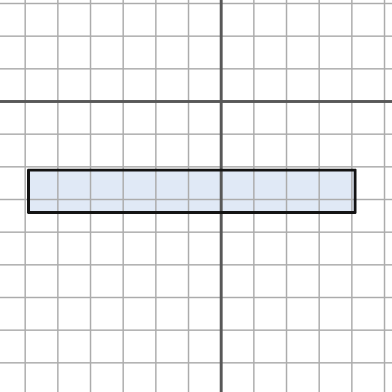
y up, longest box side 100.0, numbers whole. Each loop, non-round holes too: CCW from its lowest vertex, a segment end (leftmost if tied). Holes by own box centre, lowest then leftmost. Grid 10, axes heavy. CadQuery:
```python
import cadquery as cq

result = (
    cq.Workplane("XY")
    .moveTo(-59.0, -34.0)
    .lineTo(41.0, -34.0)
    .lineTo(41.0, -21.0)
    .lineTo(-59.0, -21.0)
    .close()
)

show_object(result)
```